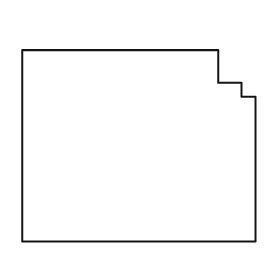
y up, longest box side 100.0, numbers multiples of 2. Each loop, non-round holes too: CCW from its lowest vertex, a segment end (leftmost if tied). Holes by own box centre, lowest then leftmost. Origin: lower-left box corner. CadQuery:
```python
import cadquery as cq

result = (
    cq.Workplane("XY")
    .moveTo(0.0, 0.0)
    .lineTo(100.0, 0.0)
    .lineTo(100.0, 62.0)
    .lineTo(94.0, 62.0)
    .lineTo(94.0, 68.0)
    .lineTo(84.0, 68.0)
    .lineTo(84.0, 82.0)
    .lineTo(0.0, 82.0)
    .close()
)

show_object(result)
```